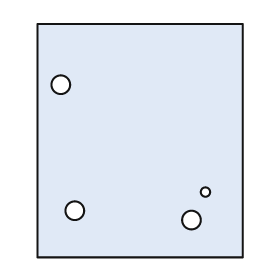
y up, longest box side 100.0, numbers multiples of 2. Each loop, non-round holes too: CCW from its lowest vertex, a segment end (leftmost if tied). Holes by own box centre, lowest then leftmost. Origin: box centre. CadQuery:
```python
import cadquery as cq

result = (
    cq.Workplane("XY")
    .moveTo(-44.0, -50.0)
    .lineTo(44.0, -50.0)
    .lineTo(44.0, 50.0)
    .lineTo(-44.0, 50.0)
    .close()
    .moveTo(22.0, -34.0)
    .circle(4.0)
    .moveTo(-28.0, -30.0)
    .circle(4.0)
    .moveTo(28.0, -22.0)
    .circle(2.0)
    .moveTo(-34.0, 24.0)
    .circle(4.0)
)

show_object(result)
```